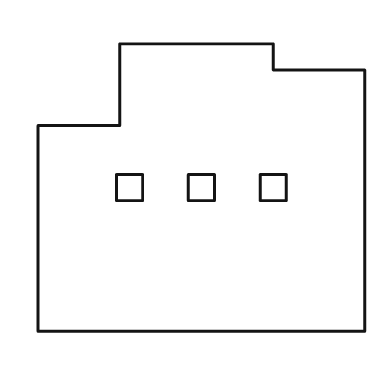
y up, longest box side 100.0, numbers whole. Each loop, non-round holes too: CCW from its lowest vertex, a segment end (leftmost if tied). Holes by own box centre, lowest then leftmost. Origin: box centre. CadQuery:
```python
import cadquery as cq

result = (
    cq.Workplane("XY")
    .moveTo(-50.0, -44.0)
    .lineTo(50.0, -44.0)
    .lineTo(50.0, 36.0)
    .lineTo(22.0, 36.0)
    .lineTo(22.0, 44.0)
    .lineTo(-25.0, 44.0)
    .lineTo(-25.0, 19.0)
    .lineTo(-50.0, 19.0)
    .close()
    .moveTo(-26.0, -4.0)
    .lineTo(-18.0, -4.0)
    .lineTo(-18.0, 4.0)
    .lineTo(-26.0, 4.0)
    .close()
    .moveTo(-4.0, -4.0)
    .lineTo(4.0, -4.0)
    .lineTo(4.0, 4.0)
    .lineTo(-4.0, 4.0)
    .close()
    .moveTo(18.0, -4.0)
    .lineTo(26.0, -4.0)
    .lineTo(26.0, 4.0)
    .lineTo(18.0, 4.0)
    .close()
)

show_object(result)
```